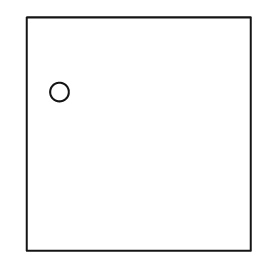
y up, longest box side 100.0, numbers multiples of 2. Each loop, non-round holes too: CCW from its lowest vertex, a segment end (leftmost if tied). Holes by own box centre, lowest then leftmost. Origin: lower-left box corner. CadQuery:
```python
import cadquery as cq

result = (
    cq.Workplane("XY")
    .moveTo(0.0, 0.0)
    .lineTo(96.0, 0.0)
    .lineTo(96.0, 100.0)
    .lineTo(0.0, 100.0)
    .close()
    .moveTo(14.0, 68.0)
    .circle(4.0)
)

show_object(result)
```